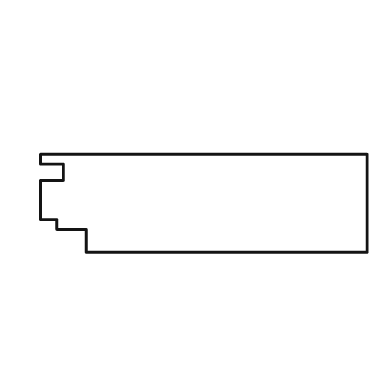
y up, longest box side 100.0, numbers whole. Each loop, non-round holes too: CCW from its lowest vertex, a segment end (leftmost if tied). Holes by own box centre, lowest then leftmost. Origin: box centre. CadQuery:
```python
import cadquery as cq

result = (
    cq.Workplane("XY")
    .moveTo(-36.0, -15.0)
    .lineTo(50.0, -15.0)
    .lineTo(50.0, 15.0)
    .lineTo(-50.0, 15.0)
    .lineTo(-50.0, 12.0)
    .lineTo(-43.0, 12.0)
    .lineTo(-43.0, 7.0)
    .lineTo(-50.0, 7.0)
    .lineTo(-50.0, -5.0)
    .lineTo(-45.0, -5.0)
    .lineTo(-45.0, -8.0)
    .lineTo(-36.0, -8.0)
    .close()
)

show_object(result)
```